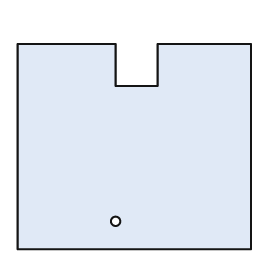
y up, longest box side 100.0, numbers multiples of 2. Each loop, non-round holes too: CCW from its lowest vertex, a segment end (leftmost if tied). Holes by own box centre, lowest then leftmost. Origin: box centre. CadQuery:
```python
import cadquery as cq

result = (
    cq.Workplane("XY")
    .moveTo(-50.0, -44.0)
    .lineTo(50.0, -44.0)
    .lineTo(50.0, 44.0)
    .lineTo(10.0, 44.0)
    .lineTo(10.0, 26.0)
    .lineTo(-8.0, 26.0)
    .lineTo(-8.0, 44.0)
    .lineTo(-50.0, 44.0)
    .close()
    .moveTo(-8.0, -32.0)
    .circle(2.0)
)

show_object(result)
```